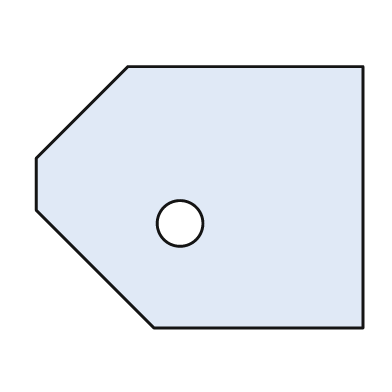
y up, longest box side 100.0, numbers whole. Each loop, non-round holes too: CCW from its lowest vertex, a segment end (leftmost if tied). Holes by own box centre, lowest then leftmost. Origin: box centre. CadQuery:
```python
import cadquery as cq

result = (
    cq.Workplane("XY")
    .moveTo(-14.0, -40.0)
    .lineTo(50.0, -40.0)
    .lineTo(50.0, 40.0)
    .lineTo(-22.0, 40.0)
    .lineTo(-50.0, 12.0)
    .lineTo(-50.0, -4.0)
    .close()
    .moveTo(-6.0, -8.0)
    .circle(7.0)
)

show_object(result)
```